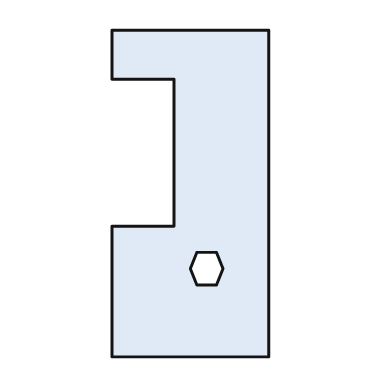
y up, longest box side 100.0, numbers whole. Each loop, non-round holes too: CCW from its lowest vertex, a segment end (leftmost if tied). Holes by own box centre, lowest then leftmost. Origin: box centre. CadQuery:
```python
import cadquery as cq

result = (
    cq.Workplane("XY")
    .moveTo(-24.0, -50.0)
    .lineTo(24.0, -50.0)
    .lineTo(24.0, 50.0)
    .lineTo(-24.0, 50.0)
    .lineTo(-24.0, 35.0)
    .lineTo(-5.0, 35.0)
    .lineTo(-5.0, -10.0)
    .lineTo(-24.0, -10.0)
    .close()
    .moveTo(2.0, -28.0)
    .lineTo(8.0, -28.0)
    .lineTo(10.0, -23.0)
    .lineTo(8.0, -18.0)
    .lineTo(2.0, -18.0)
    .lineTo(0.0, -23.0)
    .close()
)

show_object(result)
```